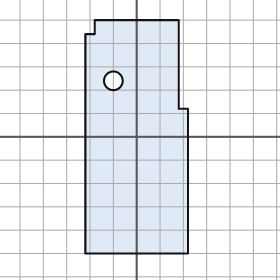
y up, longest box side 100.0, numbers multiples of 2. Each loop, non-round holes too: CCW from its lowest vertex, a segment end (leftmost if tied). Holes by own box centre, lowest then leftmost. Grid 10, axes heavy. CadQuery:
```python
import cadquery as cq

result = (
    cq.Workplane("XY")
    .moveTo(-22.0, -50.0)
    .lineTo(22.0, -50.0)
    .lineTo(22.0, 12.0)
    .lineTo(18.0, 12.0)
    .lineTo(18.0, 50.0)
    .lineTo(-18.0, 50.0)
    .lineTo(-18.0, 44.0)
    .lineTo(-22.0, 44.0)
    .close()
    .moveTo(-10.0, 24.0)
    .circle(4.0)
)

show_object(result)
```